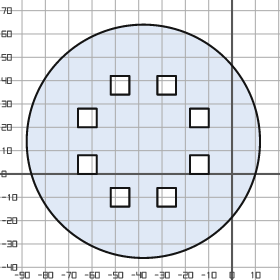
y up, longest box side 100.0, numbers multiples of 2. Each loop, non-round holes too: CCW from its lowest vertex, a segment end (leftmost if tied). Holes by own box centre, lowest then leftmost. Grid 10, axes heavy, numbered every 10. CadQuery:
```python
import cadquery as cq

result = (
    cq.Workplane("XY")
    .moveTo(-38.0, 14.0)
    .circle(50.0)
    .moveTo(-52.0, -14.0)
    .lineTo(-44.0, -14.0)
    .lineTo(-44.0, -6.0)
    .lineTo(-52.0, -6.0)
    .close()
    .moveTo(-32.0, -14.0)
    .lineTo(-24.0, -14.0)
    .lineTo(-24.0, -6.0)
    .lineTo(-32.0, -6.0)
    .close()
    .moveTo(-66.0, 0.0)
    .lineTo(-58.0, 0.0)
    .lineTo(-58.0, 8.0)
    .lineTo(-66.0, 8.0)
    .close()
    .moveTo(-18.0, 0.0)
    .lineTo(-10.0, 0.0)
    .lineTo(-10.0, 8.0)
    .lineTo(-18.0, 8.0)
    .close()
    .moveTo(-66.0, 20.0)
    .lineTo(-58.0, 20.0)
    .lineTo(-58.0, 28.0)
    .lineTo(-66.0, 28.0)
    .close()
    .moveTo(-18.0, 20.0)
    .lineTo(-10.0, 20.0)
    .lineTo(-10.0, 28.0)
    .lineTo(-18.0, 28.0)
    .close()
    .moveTo(-52.0, 34.0)
    .lineTo(-44.0, 34.0)
    .lineTo(-44.0, 42.0)
    .lineTo(-52.0, 42.0)
    .close()
    .moveTo(-32.0, 34.0)
    .lineTo(-24.0, 34.0)
    .lineTo(-24.0, 42.0)
    .lineTo(-32.0, 42.0)
    .close()
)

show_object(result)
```